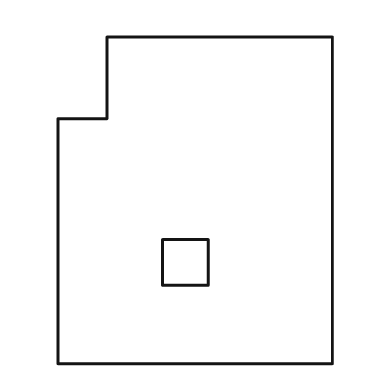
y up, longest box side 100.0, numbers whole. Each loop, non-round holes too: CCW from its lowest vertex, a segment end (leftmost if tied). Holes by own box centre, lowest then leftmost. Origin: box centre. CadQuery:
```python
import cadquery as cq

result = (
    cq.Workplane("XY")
    .moveTo(-42.0, -50.0)
    .lineTo(42.0, -50.0)
    .lineTo(42.0, 50.0)
    .lineTo(-27.0, 50.0)
    .lineTo(-27.0, 25.0)
    .lineTo(-42.0, 25.0)
    .close()
    .moveTo(-10.0, -26.0)
    .lineTo(4.0, -26.0)
    .lineTo(4.0, -12.0)
    .lineTo(-10.0, -12.0)
    .close()
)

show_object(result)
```